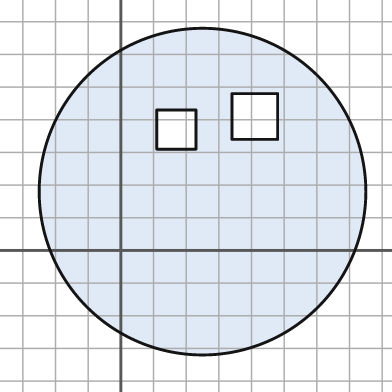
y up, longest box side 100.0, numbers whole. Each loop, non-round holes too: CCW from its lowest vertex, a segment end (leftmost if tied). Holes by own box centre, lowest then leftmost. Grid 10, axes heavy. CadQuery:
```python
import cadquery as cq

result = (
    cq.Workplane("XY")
    .moveTo(25.0, 18.0)
    .circle(50.0)
    .moveTo(11.0, 31.0)
    .lineTo(23.0, 31.0)
    .lineTo(23.0, 43.0)
    .lineTo(11.0, 43.0)
    .close()
    .moveTo(34.0, 34.0)
    .lineTo(48.0, 34.0)
    .lineTo(48.0, 48.0)
    .lineTo(34.0, 48.0)
    .close()
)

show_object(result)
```